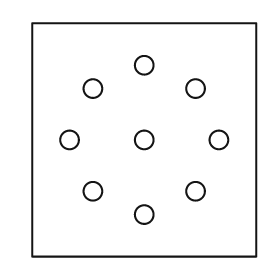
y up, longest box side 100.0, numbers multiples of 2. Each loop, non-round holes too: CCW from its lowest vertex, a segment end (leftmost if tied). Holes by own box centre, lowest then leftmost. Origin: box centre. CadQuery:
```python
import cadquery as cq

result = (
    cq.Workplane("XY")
    .moveTo(-48.0, -50.0)
    .lineTo(48.0, -50.0)
    .lineTo(48.0, 50.0)
    .lineTo(-48.0, 50.0)
    .close()
    .moveTo(0.0, -32.0)
    .circle(4.0)
    .moveTo(-22.0, -22.0)
    .circle(4.0)
    .moveTo(22.0, -22.0)
    .circle(4.0)
    .moveTo(-32.0, 0.0)
    .circle(4.0)
    .moveTo(0.0, 0.0)
    .circle(4.0)
    .moveTo(32.0, 0.0)
    .circle(4.0)
    .moveTo(-22.0, 22.0)
    .circle(4.0)
    .moveTo(22.0, 22.0)
    .circle(4.0)
    .moveTo(0.0, 32.0)
    .circle(4.0)
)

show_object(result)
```